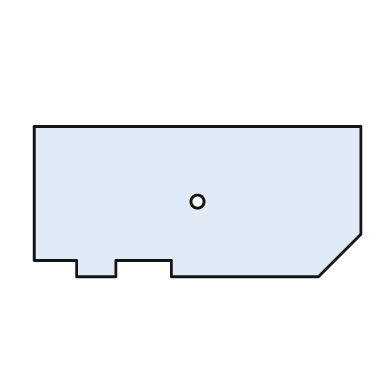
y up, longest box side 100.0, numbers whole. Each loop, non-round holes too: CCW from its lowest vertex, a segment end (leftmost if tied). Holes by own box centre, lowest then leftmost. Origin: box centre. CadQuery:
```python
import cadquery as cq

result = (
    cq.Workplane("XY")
    .moveTo(-37.0, -23.0)
    .lineTo(-25.0, -23.0)
    .lineTo(-25.0, -18.0)
    .lineTo(-8.0, -18.0)
    .lineTo(-8.0, -23.0)
    .lineTo(37.0, -23.0)
    .lineTo(50.0, -10.0)
    .lineTo(50.0, 23.0)
    .lineTo(-50.0, 23.0)
    .lineTo(-50.0, -18.0)
    .lineTo(-37.0, -18.0)
    .close()
    .moveTo(0.0, 0.0)
    .circle(2.0)
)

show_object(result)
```